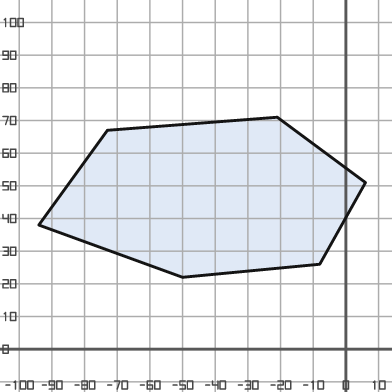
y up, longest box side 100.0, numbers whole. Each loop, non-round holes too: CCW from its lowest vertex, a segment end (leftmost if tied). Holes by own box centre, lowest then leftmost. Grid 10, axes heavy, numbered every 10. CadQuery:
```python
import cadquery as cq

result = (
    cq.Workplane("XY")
    .moveTo(-50.0, 22.0)
    .lineTo(-8.0, 26.0)
    .lineTo(6.0, 51.0)
    .lineTo(-21.0, 71.0)
    .lineTo(-73.0, 67.0)
    .lineTo(-94.0, 38.0)
    .close()
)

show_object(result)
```